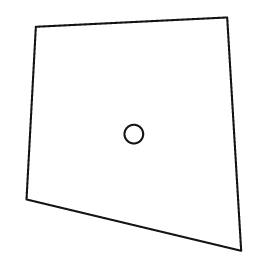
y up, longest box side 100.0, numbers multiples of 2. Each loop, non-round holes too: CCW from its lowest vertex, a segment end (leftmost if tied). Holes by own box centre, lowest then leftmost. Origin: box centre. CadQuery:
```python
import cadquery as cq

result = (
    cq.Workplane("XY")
    .moveTo(46.0, -50.0)
    .lineTo(40.0, 50.0)
    .lineTo(-42.0, 46.0)
    .lineTo(-46.0, -28.0)
    .close()
    .moveTo(0.0, 0.0)
    .circle(4.0)
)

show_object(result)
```